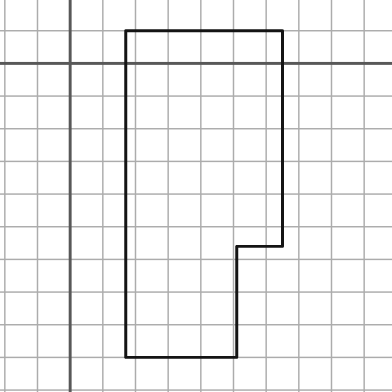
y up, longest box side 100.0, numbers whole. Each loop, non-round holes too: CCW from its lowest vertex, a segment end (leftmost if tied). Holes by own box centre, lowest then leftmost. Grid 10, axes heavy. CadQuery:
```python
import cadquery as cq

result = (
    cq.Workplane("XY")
    .moveTo(17.0, -90.0)
    .lineTo(51.0, -90.0)
    .lineTo(51.0, -56.0)
    .lineTo(65.0, -56.0)
    .lineTo(65.0, 10.0)
    .lineTo(17.0, 10.0)
    .close()
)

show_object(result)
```